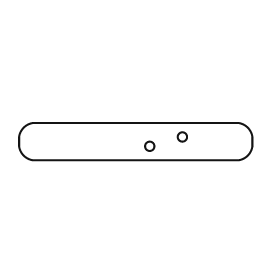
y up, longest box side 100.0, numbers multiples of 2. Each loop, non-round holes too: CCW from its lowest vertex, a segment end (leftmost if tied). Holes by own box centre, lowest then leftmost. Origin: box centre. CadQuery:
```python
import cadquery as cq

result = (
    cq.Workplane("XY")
    .moveTo(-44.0, -8.0)
    .lineTo(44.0, -8.0)
    .threePointArc((48.0, -6.0), (50.0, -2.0))
    .lineTo(50.0, 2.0)
    .threePointArc((48.0, 6.0), (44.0, 8.0))
    .lineTo(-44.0, 8.0)
    .threePointArc((-48.0, 6.0), (-50.0, 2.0))
    .lineTo(-50.0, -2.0)
    .threePointArc((-48.0, -6.0), (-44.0, -8.0))
    .close()
    .moveTo(6.0, -2.0)
    .circle(2.0)
    .moveTo(20.0, 2.0)
    .circle(2.0)
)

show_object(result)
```